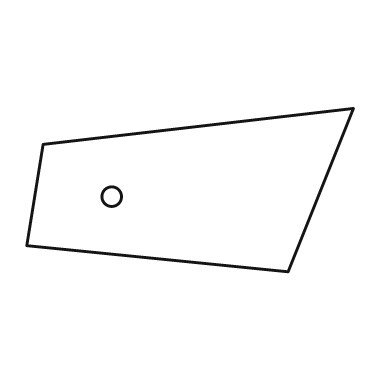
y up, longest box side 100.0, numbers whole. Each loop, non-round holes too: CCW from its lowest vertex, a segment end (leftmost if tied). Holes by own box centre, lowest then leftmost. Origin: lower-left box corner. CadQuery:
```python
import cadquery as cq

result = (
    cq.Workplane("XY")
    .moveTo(80.0, 0.0)
    .lineTo(100.0, 50.0)
    .lineTo(5.0, 39.0)
    .lineTo(0.0, 8.0)
    .close()
    .moveTo(26.0, 23.0)
    .circle(3.0)
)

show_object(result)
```